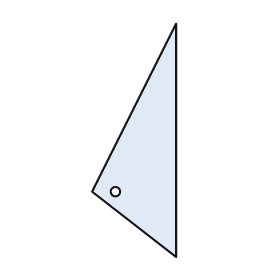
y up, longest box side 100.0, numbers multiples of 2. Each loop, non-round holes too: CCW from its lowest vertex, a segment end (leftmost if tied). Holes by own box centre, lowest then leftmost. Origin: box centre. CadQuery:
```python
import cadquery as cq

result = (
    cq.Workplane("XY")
    .moveTo(18.0, -50.0)
    .lineTo(18.0, 50.0)
    .lineTo(-18.0, -22.0)
    .close()
    .moveTo(-8.0, -22.0)
    .circle(2.0)
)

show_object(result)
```